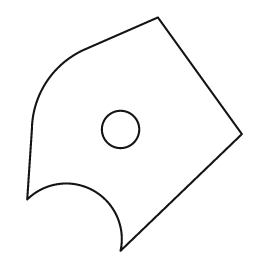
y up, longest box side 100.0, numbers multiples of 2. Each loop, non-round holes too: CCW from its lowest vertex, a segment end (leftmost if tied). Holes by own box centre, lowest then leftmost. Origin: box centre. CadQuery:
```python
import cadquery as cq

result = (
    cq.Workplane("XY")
    .moveTo(-6.0, -50.0)
    .lineTo(46.0, 0.0)
    .lineTo(10.0, 50.0)
    .lineTo(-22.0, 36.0)
    .threePointArc((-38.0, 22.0), (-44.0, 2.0))
    .lineTo(-46.0, -28.0)
    .threePointArc((-18.0, -24.0), (-6.0, -50.0))
    .close()
    .moveTo(-6.0, 2.0)
    .circle(8.0)
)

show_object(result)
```